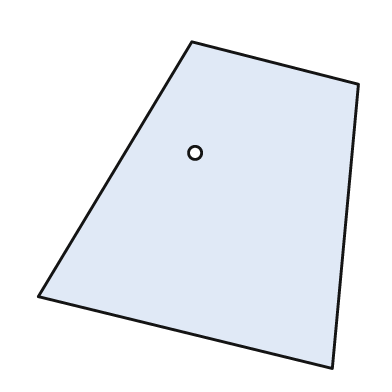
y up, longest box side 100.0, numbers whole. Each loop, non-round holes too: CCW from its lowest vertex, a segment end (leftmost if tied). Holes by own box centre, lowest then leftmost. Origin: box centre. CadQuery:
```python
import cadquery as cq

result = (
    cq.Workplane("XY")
    .moveTo(41.0, -50.0)
    .lineTo(49.0, 37.0)
    .lineTo(-2.0, 50.0)
    .lineTo(-49.0, -28.0)
    .close()
    .moveTo(-1.0, 16.0)
    .circle(2.0)
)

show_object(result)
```